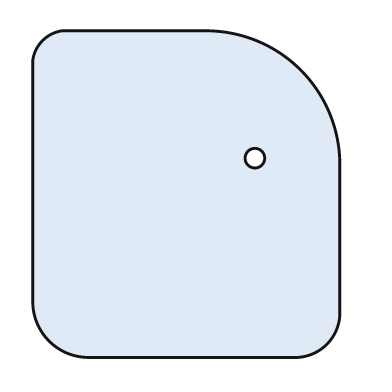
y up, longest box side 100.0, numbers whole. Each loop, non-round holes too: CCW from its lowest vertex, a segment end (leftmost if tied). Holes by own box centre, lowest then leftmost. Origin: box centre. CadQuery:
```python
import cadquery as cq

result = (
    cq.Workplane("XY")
    .moveTo(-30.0, -50.0)
    .lineTo(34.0, -50.0)
    .threePointArc((43.0, -46.0), (47.0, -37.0))
    .lineTo(47.0, 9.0)
    .threePointArc((35.0, 38.0), (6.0, 50.0))
    .lineTo(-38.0, 50.0)
    .threePointArc((-44.0, 47.0), (-47.0, 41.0))
    .lineTo(-47.0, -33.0)
    .threePointArc((-42.0, -45.0), (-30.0, -50.0))
    .close()
    .moveTo(21.0, 11.0)
    .circle(3.0)
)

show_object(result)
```